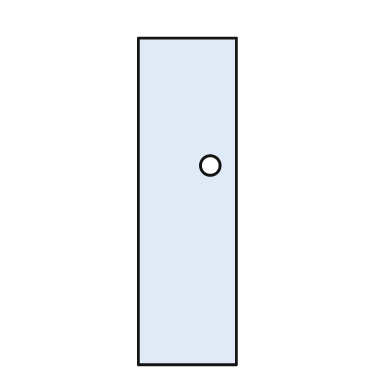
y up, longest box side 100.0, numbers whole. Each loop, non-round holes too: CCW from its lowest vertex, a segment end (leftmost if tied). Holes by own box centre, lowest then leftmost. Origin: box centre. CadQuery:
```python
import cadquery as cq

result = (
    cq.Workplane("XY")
    .moveTo(-15.0, -50.0)
    .lineTo(15.0, -50.0)
    .lineTo(15.0, 50.0)
    .lineTo(-15.0, 50.0)
    .close()
    .moveTo(7.0, 11.0)
    .circle(3.0)
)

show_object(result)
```